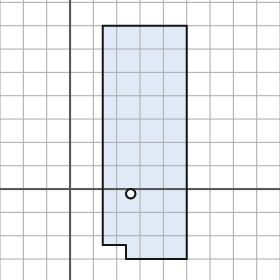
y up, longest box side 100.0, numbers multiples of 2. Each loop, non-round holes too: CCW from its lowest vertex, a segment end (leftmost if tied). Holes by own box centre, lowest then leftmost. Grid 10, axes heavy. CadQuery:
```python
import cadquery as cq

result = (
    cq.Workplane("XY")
    .moveTo(24.0, -30.0)
    .lineTo(50.0, -30.0)
    .lineTo(50.0, 70.0)
    .lineTo(14.0, 70.0)
    .lineTo(14.0, -24.0)
    .lineTo(24.0, -24.0)
    .close()
    .moveTo(26.0, -2.0)
    .circle(2.0)
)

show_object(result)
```